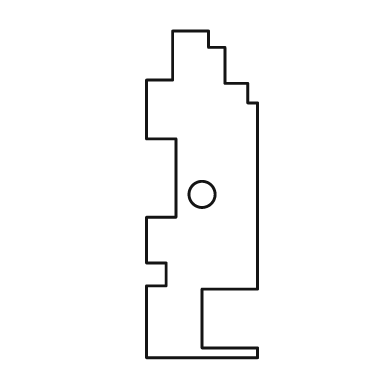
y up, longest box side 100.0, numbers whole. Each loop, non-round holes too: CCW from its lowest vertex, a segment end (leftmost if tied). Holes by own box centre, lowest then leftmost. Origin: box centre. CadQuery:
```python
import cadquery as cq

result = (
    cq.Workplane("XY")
    .moveTo(-17.0, -50.0)
    .lineTo(17.0, -50.0)
    .lineTo(17.0, -47.0)
    .lineTo(0.0, -47.0)
    .lineTo(0.0, -29.0)
    .lineTo(17.0, -29.0)
    .lineTo(17.0, 28.0)
    .lineTo(14.0, 28.0)
    .lineTo(14.0, 34.0)
    .lineTo(7.0, 34.0)
    .lineTo(7.0, 45.0)
    .lineTo(2.0, 45.0)
    .lineTo(2.0, 50.0)
    .lineTo(-9.0, 50.0)
    .lineTo(-9.0, 35.0)
    .lineTo(-17.0, 35.0)
    .lineTo(-17.0, 17.0)
    .lineTo(-8.0, 17.0)
    .lineTo(-8.0, -7.0)
    .lineTo(-17.0, -7.0)
    .lineTo(-17.0, -21.0)
    .lineTo(-11.0, -21.0)
    .lineTo(-11.0, -28.0)
    .lineTo(-17.0, -28.0)
    .close()
    .moveTo(0.0, 0.0)
    .circle(4.0)
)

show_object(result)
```